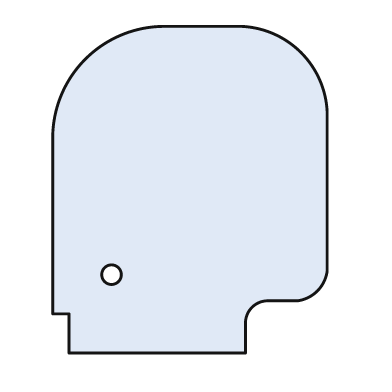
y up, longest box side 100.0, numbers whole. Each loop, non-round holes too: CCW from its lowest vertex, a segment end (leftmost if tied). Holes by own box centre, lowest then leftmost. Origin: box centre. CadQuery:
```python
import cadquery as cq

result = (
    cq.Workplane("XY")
    .moveTo(-37.0, -50.0)
    .lineTo(17.0, -50.0)
    .lineTo(17.0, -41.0)
    .threePointArc((19.0, -36.0), (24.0, -34.0))
    .lineTo(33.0, -34.0)
    .threePointArc((39.0, -31.0), (42.0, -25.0))
    .lineTo(42.0, 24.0)
    .threePointArc((34.0, 42.0), (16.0, 50.0))
    .lineTo(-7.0, 50.0)
    .threePointArc((-32.0, 40.0), (-42.0, 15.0))
    .lineTo(-42.0, -38.0)
    .lineTo(-37.0, -38.0)
    .close()
    .moveTo(-24.0, -26.0)
    .circle(3.0)
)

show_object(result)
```